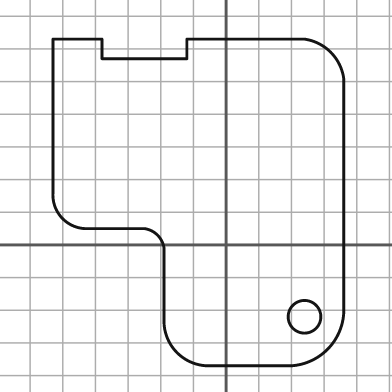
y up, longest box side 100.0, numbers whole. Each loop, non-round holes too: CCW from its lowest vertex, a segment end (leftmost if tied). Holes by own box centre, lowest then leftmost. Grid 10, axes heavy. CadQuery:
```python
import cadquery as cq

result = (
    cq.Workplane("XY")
    .moveTo(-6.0, -37.0)
    .lineTo(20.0, -37.0)
    .threePointArc((31.0, -32.0), (36.0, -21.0))
    .lineTo(36.0, 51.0)
    .threePointArc((32.0, 59.0), (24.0, 63.0))
    .lineTo(-12.0, 63.0)
    .lineTo(-12.0, 57.0)
    .lineTo(-38.0, 57.0)
    .lineTo(-38.0, 63.0)
    .lineTo(-53.0, 63.0)
    .lineTo(-53.0, 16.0)
    .threePointArc((-50.0, 8.0), (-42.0, 5.0))
    .lineTo(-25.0, 5.0)
    .threePointArc((-21.0, 3.0), (-19.0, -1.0))
    .lineTo(-19.0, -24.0)
    .threePointArc((-15.0, -33.0), (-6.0, -37.0))
    .close()
    .moveTo(24.0, -22.0)
    .circle(5.0)
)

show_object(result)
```